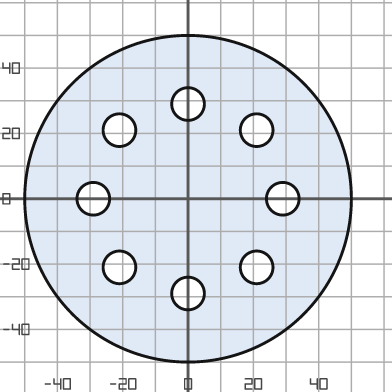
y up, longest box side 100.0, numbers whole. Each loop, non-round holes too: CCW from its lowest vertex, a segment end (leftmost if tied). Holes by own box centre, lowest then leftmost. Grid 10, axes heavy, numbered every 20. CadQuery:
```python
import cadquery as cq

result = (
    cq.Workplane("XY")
    .moveTo(0.0, 0.0)
    .circle(50.0)
    .moveTo(0.0, -29.0)
    .circle(5.0)
    .moveTo(-21.0, -21.0)
    .circle(5.0)
    .moveTo(21.0, -21.0)
    .circle(5.0)
    .moveTo(-29.0, 0.0)
    .circle(5.0)
    .moveTo(29.0, 0.0)
    .circle(5.0)
    .moveTo(-21.0, 21.0)
    .circle(5.0)
    .moveTo(21.0, 21.0)
    .circle(5.0)
    .moveTo(0.0, 29.0)
    .circle(5.0)
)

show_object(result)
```